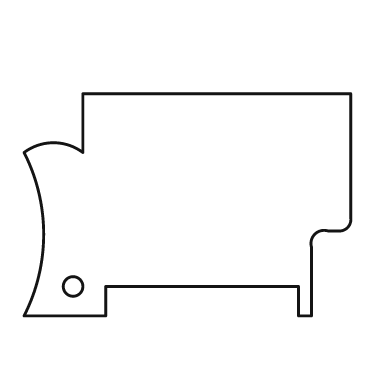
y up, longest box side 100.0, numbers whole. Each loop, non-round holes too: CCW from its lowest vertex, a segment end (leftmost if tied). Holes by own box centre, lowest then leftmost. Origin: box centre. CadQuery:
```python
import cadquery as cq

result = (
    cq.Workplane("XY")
    .moveTo(-50.0, -34.0)
    .lineTo(-25.0, -34.0)
    .lineTo(-25.0, -25.0)
    .lineTo(34.0, -25.0)
    .lineTo(34.0, -34.0)
    .lineTo(38.0, -34.0)
    .lineTo(38.0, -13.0)
    .threePointArc((39.0, -9.0), (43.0, -8.0))
    .lineTo(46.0, -8.0)
    .threePointArc((49.0, -7.0), (50.0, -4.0))
    .lineTo(50.0, 34.0)
    .lineTo(-32.0, 34.0)
    .lineTo(-32.0, 16.0)
    .threePointArc((-41.0, 19.0), (-50.0, 16.0))
    .threePointArc((-44.0, -9.0), (-50.0, -34.0))
    .close()
    .moveTo(-35.0, -25.0)
    .circle(3.0)
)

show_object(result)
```